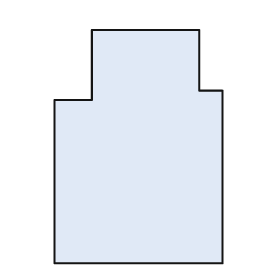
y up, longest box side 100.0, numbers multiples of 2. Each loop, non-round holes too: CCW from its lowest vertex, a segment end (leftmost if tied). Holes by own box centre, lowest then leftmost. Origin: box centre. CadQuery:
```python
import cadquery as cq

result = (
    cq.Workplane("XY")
    .moveTo(-36.0, -50.0)
    .lineTo(36.0, -50.0)
    .lineTo(36.0, 24.0)
    .lineTo(26.0, 24.0)
    .lineTo(26.0, 50.0)
    .lineTo(-20.0, 50.0)
    .lineTo(-20.0, 20.0)
    .lineTo(-36.0, 20.0)
    .close()
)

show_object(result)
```